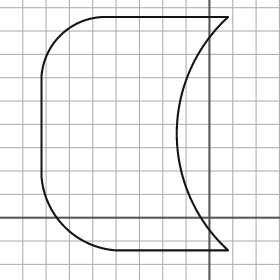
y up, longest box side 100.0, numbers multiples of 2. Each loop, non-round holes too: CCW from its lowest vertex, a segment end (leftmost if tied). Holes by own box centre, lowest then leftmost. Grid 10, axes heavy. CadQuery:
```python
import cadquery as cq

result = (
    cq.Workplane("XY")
    .moveTo(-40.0, -14.0)
    .lineTo(8.0, -14.0)
    .threePointArc((-14.0, 36.0), (8.0, 86.0))
    .lineTo(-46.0, 86.0)
    .threePointArc((-64.0, 78.0), (-72.0, 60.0))
    .lineTo(-72.0, 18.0)
    .threePointArc((-62.0, -4.0), (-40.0, -14.0))
    .close()
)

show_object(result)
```